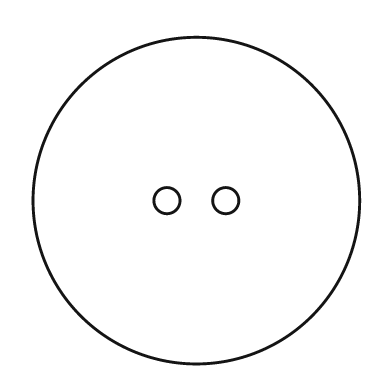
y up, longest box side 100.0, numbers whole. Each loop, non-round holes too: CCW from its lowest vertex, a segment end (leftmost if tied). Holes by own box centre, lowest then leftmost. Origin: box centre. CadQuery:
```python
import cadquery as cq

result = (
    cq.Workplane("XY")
    .moveTo(0.0, 0.0)
    .circle(50.0)
    .moveTo(-9.0, 0.0)
    .circle(4.0)
    .moveTo(9.0, 0.0)
    .circle(4.0)
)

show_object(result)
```